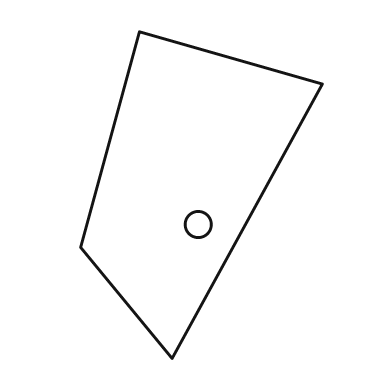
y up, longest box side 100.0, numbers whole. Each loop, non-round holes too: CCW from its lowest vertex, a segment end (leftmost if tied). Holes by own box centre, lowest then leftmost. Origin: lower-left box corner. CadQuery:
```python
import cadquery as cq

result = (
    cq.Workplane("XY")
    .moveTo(28.0, 0.0)
    .lineTo(74.0, 84.0)
    .lineTo(18.0, 100.0)
    .lineTo(0.0, 34.0)
    .close()
    .moveTo(36.0, 41.0)
    .circle(4.0)
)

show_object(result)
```